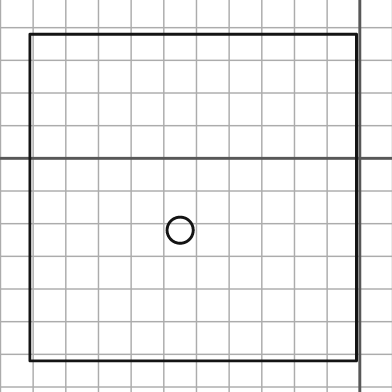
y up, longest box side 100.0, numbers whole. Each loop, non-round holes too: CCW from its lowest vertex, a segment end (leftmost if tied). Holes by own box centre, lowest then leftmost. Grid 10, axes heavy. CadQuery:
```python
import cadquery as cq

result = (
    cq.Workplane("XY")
    .moveTo(-101.0, -62.0)
    .lineTo(-1.0, -62.0)
    .lineTo(-1.0, 38.0)
    .lineTo(-101.0, 38.0)
    .close()
    .moveTo(-55.0, -22.0)
    .circle(4.0)
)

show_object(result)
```